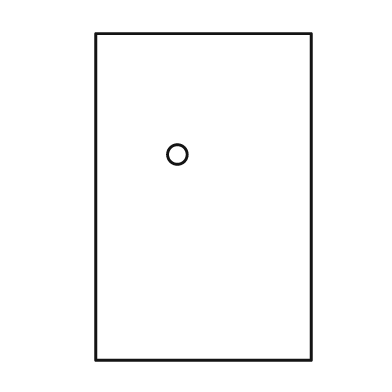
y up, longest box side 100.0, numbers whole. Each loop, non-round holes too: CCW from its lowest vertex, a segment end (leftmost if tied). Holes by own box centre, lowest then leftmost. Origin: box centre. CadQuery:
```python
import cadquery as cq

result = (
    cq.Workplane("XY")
    .moveTo(-33.0, -50.0)
    .lineTo(33.0, -50.0)
    .lineTo(33.0, 50.0)
    .lineTo(-33.0, 50.0)
    .close()
    .moveTo(-8.0, 13.0)
    .circle(3.0)
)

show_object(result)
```